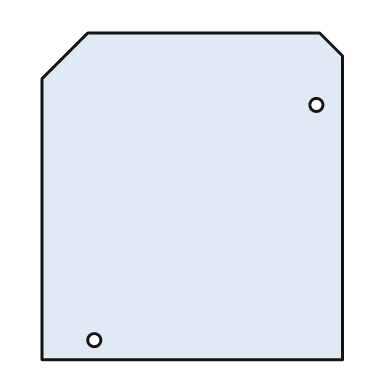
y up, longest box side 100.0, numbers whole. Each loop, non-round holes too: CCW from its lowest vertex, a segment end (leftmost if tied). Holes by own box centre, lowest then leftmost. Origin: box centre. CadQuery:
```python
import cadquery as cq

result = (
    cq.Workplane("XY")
    .moveTo(-46.0, -50.0)
    .lineTo(46.0, -50.0)
    .lineTo(46.0, 43.0)
    .lineTo(39.0, 50.0)
    .lineTo(-32.0, 50.0)
    .lineTo(-46.0, 36.0)
    .close()
    .moveTo(-30.0, -44.0)
    .circle(2.0)
    .moveTo(38.0, 28.0)
    .circle(2.0)
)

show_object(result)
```